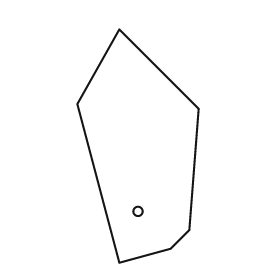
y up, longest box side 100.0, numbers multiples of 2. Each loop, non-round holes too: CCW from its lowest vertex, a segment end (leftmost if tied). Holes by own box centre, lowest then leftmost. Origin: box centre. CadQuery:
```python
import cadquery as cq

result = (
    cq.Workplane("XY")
    .moveTo(-8.0, -50.0)
    .lineTo(14.0, -44.0)
    .lineTo(22.0, -36.0)
    .lineTo(26.0, 16.0)
    .lineTo(-8.0, 50.0)
    .lineTo(-26.0, 18.0)
    .close()
    .moveTo(0.0, -28.0)
    .circle(2.0)
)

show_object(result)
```